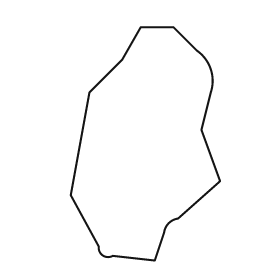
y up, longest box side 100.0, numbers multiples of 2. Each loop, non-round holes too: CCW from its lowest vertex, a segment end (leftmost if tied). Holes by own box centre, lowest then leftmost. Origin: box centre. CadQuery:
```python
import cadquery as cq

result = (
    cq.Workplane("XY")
    .moveTo(4.0, -50.0)
    .lineTo(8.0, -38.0)
    .threePointArc((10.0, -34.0), (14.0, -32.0))
    .lineTo(32.0, -16.0)
    .lineTo(24.0, 6.0)
    .lineTo(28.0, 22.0)
    .threePointArc((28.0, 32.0), (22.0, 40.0))
    .lineTo(12.0, 50.0)
    .lineTo(-2.0, 50.0)
    .lineTo(-10.0, 36.0)
    .lineTo(-24.0, 22.0)
    .lineTo(-32.0, -22.0)
    .lineTo(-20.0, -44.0)
    .threePointArc((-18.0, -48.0), (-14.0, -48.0))
    .close()
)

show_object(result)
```